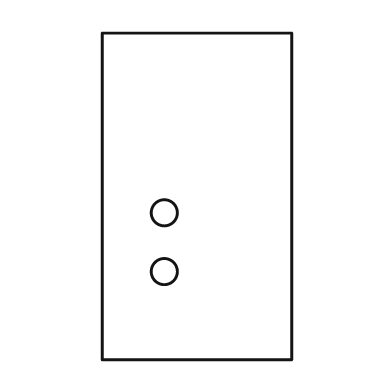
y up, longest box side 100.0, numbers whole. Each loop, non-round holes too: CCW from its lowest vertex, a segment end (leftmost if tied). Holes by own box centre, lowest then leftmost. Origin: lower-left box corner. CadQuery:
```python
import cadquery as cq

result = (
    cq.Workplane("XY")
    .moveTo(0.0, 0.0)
    .lineTo(58.0, 0.0)
    .lineTo(58.0, 100.0)
    .lineTo(0.0, 100.0)
    .close()
    .moveTo(19.0, 27.0)
    .circle(4.0)
    .moveTo(19.0, 45.0)
    .circle(4.0)
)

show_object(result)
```